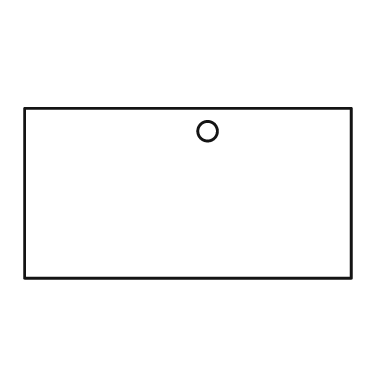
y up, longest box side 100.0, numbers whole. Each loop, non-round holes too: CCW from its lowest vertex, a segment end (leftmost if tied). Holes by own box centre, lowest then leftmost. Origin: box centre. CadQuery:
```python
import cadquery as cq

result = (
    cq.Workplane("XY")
    .moveTo(-50.0, -26.0)
    .lineTo(50.0, -26.0)
    .lineTo(50.0, 26.0)
    .lineTo(-50.0, 26.0)
    .close()
    .moveTo(6.0, 19.0)
    .circle(3.0)
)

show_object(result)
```